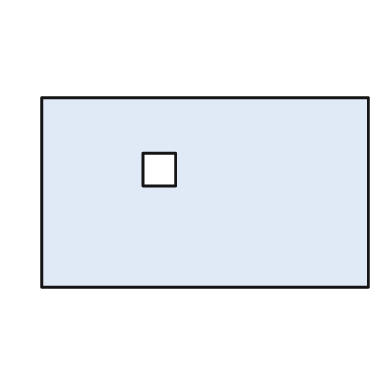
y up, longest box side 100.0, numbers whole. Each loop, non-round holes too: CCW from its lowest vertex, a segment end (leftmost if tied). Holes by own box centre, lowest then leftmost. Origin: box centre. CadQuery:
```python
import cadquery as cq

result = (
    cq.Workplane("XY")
    .moveTo(-50.0, -29.0)
    .lineTo(50.0, -29.0)
    .lineTo(50.0, 29.0)
    .lineTo(-50.0, 29.0)
    .close()
    .moveTo(-19.0, 2.0)
    .lineTo(-9.0, 2.0)
    .lineTo(-9.0, 12.0)
    .lineTo(-19.0, 12.0)
    .close()
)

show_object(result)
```